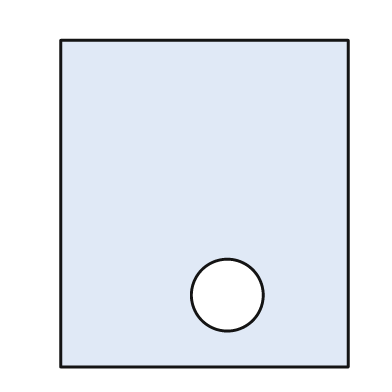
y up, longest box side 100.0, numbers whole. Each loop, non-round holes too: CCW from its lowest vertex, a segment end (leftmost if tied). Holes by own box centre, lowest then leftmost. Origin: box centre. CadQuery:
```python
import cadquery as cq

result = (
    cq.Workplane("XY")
    .moveTo(-44.0, -50.0)
    .lineTo(44.0, -50.0)
    .lineTo(44.0, 50.0)
    .lineTo(-44.0, 50.0)
    .close()
    .moveTo(7.0, -28.0)
    .circle(11.0)
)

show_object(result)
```